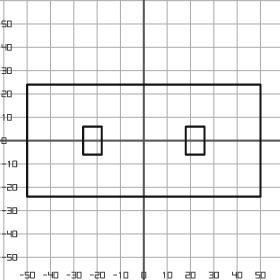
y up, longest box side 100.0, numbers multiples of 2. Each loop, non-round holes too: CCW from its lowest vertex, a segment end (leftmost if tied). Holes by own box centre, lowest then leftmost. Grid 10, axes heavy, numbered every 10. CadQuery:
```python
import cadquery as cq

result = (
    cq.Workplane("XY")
    .moveTo(-50.0, -24.0)
    .lineTo(50.0, -24.0)
    .lineTo(50.0, 24.0)
    .lineTo(-50.0, 24.0)
    .close()
    .moveTo(-26.0, -6.0)
    .lineTo(-18.0, -6.0)
    .lineTo(-18.0, 6.0)
    .lineTo(-26.0, 6.0)
    .close()
    .moveTo(18.0, -6.0)
    .lineTo(26.0, -6.0)
    .lineTo(26.0, 6.0)
    .lineTo(18.0, 6.0)
    .close()
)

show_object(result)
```